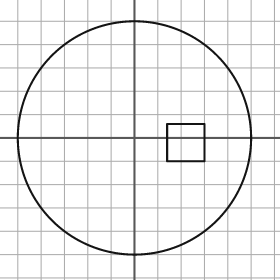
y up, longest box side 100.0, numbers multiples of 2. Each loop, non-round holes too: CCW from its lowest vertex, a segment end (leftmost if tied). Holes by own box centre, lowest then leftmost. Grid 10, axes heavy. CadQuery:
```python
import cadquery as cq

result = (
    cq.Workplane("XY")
    .moveTo(0.0, 0.0)
    .circle(50.0)
    .moveTo(14.0, -10.0)
    .lineTo(30.0, -10.0)
    .lineTo(30.0, 6.0)
    .lineTo(14.0, 6.0)
    .close()
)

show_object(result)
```